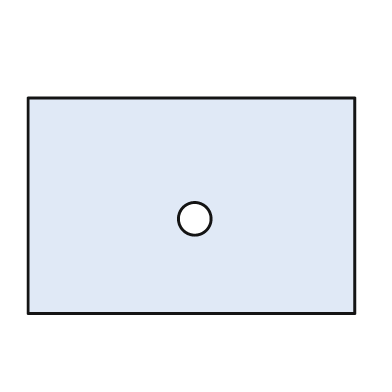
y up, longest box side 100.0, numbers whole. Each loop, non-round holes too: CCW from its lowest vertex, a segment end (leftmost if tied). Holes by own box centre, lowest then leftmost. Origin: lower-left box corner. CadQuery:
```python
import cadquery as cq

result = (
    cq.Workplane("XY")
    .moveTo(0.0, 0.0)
    .lineTo(100.0, 0.0)
    .lineTo(100.0, 66.0)
    .lineTo(0.0, 66.0)
    .close()
    .moveTo(51.0, 29.0)
    .circle(5.0)
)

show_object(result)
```